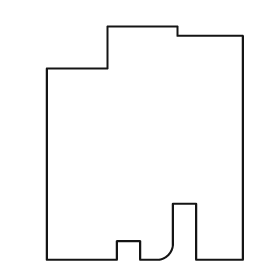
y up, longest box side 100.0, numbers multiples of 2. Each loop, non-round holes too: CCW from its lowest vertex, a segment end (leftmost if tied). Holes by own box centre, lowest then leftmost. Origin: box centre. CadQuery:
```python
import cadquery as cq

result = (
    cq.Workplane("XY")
    .moveTo(-42.0, -50.0)
    .lineTo(-12.0, -50.0)
    .lineTo(-12.0, -42.0)
    .lineTo(-2.0, -42.0)
    .lineTo(-2.0, -50.0)
    .lineTo(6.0, -50.0)
    .threePointArc((10.0, -48.0), (12.0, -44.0))
    .lineTo(12.0, -26.0)
    .lineTo(22.0, -26.0)
    .lineTo(22.0, -50.0)
    .lineTo(42.0, -50.0)
    .lineTo(42.0, 46.0)
    .lineTo(14.0, 46.0)
    .lineTo(14.0, 50.0)
    .lineTo(-16.0, 50.0)
    .lineTo(-16.0, 32.0)
    .lineTo(-42.0, 32.0)
    .close()
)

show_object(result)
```